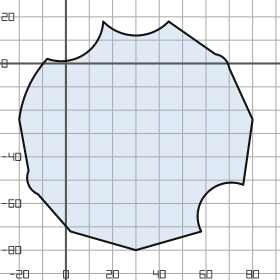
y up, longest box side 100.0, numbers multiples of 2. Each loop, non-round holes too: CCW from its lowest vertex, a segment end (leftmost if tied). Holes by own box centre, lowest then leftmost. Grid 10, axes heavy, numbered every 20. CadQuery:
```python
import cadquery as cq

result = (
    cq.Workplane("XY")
    .moveTo(30.0, -80.0)
    .lineTo(58.0, -72.0)
    .threePointArc((60.0, -56.0), (76.0, -52.0))
    .lineTo(80.0, -24.0)
    .lineTo(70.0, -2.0)
    .threePointArc((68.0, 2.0), (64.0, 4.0))
    .lineTo(44.0, 18.0)
    .threePointArc((30.0, 12.0), (16.0, 18.0))
    .threePointArc((8.0, 4.0), (-8.0, 2.0))
    .threePointArc((-16.0, -10.0), (-20.0, -24.0))
    .lineTo(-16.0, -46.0)
    .threePointArc((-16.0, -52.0), (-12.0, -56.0))
    .lineTo(2.0, -72.0)
    .close()
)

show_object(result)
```